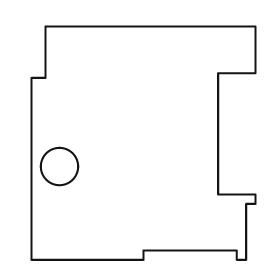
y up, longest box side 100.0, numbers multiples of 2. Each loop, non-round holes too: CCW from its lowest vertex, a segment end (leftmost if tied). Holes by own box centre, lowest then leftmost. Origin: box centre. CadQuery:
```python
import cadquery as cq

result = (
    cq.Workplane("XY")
    .moveTo(-48.0, -50.0)
    .lineTo(0.0, -50.0)
    .lineTo(0.0, -46.0)
    .lineTo(40.0, -46.0)
    .lineTo(40.0, -50.0)
    .lineTo(44.0, -50.0)
    .lineTo(44.0, -26.0)
    .lineTo(48.0, -26.0)
    .lineTo(48.0, -22.0)
    .lineTo(32.0, -22.0)
    .lineTo(32.0, 30.0)
    .lineTo(48.0, 30.0)
    .lineTo(48.0, 50.0)
    .lineTo(-42.0, 50.0)
    .lineTo(-42.0, 28.0)
    .lineTo(-48.0, 28.0)
    .close()
    .moveTo(-36.0, -10.0)
    .circle(8.0)
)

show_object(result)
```